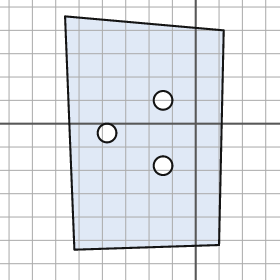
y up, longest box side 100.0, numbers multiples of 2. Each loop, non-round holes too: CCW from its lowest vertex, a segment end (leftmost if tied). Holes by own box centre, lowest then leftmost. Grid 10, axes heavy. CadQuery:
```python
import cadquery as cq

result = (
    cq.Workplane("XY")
    .moveTo(-52.0, -54.0)
    .lineTo(10.0, -52.0)
    .lineTo(12.0, 40.0)
    .lineTo(-56.0, 46.0)
    .close()
    .moveTo(-14.0, -18.0)
    .circle(4.0)
    .moveTo(-38.0, -4.0)
    .circle(4.0)
    .moveTo(-14.0, 10.0)
    .circle(4.0)
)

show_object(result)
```